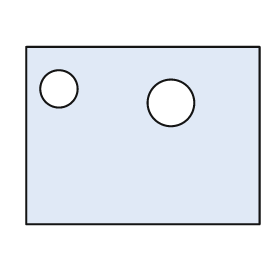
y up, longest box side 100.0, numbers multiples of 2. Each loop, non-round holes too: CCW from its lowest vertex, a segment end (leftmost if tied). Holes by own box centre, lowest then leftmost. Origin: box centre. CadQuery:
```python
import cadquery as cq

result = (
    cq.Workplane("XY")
    .moveTo(-50.0, -38.0)
    .lineTo(50.0, -38.0)
    .lineTo(50.0, 38.0)
    .lineTo(-50.0, 38.0)
    .close()
    .moveTo(12.0, 14.0)
    .circle(10.0)
    .moveTo(-36.0, 20.0)
    .circle(8.0)
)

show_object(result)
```